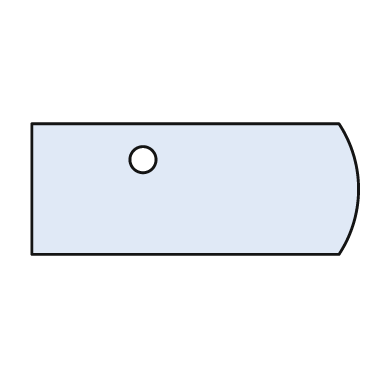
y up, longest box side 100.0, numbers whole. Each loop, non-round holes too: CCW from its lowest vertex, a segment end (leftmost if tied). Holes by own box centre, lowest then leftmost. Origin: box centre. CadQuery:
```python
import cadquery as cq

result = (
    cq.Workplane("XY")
    .moveTo(-50.0, -20.0)
    .lineTo(44.0, -20.0)
    .threePointArc((50.0, 0.0), (44.0, 20.0))
    .lineTo(-50.0, 20.0)
    .close()
    .moveTo(-16.0, 9.0)
    .circle(4.0)
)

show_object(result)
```